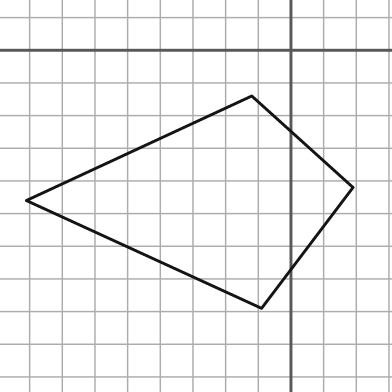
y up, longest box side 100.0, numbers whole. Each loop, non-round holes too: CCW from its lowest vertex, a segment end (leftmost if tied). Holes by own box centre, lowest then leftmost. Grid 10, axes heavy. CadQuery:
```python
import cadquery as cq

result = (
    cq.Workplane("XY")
    .moveTo(-9.0, -79.0)
    .lineTo(19.0, -42.0)
    .lineTo(-12.0, -14.0)
    .lineTo(-81.0, -46.0)
    .close()
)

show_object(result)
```